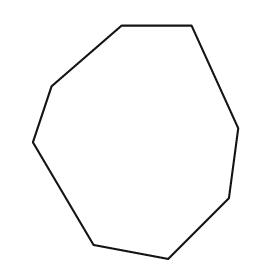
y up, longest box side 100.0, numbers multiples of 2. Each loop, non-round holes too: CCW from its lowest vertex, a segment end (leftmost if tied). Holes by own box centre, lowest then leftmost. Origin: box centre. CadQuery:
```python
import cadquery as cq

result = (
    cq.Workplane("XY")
    .moveTo(14.0, -50.0)
    .lineTo(40.0, -24.0)
    .lineTo(44.0, 6.0)
    .lineTo(24.0, 50.0)
    .lineTo(-6.0, 50.0)
    .lineTo(-36.0, 24.0)
    .lineTo(-44.0, 0.0)
    .lineTo(-18.0, -44.0)
    .close()
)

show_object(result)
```